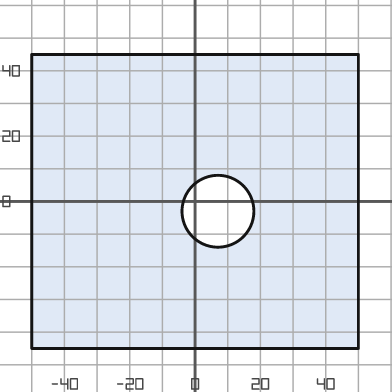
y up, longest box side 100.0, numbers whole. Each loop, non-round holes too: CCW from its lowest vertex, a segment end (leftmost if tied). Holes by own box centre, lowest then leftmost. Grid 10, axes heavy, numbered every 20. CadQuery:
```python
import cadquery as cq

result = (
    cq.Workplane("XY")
    .moveTo(-50.0, -45.0)
    .lineTo(50.0, -45.0)
    .lineTo(50.0, 45.0)
    .lineTo(-50.0, 45.0)
    .close()
    .moveTo(7.0, -3.0)
    .circle(11.0)
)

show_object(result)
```